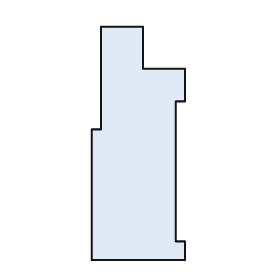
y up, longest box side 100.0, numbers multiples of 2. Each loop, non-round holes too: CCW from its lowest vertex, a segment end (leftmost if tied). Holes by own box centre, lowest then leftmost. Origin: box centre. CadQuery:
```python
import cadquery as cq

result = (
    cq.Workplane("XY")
    .moveTo(-20.0, -50.0)
    .lineTo(20.0, -50.0)
    .lineTo(20.0, -42.0)
    .lineTo(16.0, -42.0)
    .lineTo(16.0, 18.0)
    .lineTo(20.0, 18.0)
    .lineTo(20.0, 32.0)
    .lineTo(2.0, 32.0)
    .lineTo(2.0, 50.0)
    .lineTo(-16.0, 50.0)
    .lineTo(-16.0, 6.0)
    .lineTo(-20.0, 6.0)
    .close()
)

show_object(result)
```